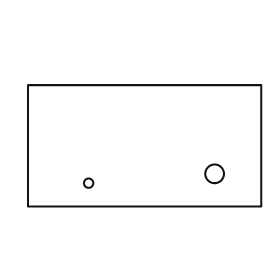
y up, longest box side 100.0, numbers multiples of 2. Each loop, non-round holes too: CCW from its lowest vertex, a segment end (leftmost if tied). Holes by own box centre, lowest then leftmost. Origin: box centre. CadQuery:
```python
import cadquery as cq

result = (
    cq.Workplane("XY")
    .moveTo(-50.0, -26.0)
    .lineTo(50.0, -26.0)
    .lineTo(50.0, 26.0)
    .lineTo(-50.0, 26.0)
    .close()
    .moveTo(-24.0, -16.0)
    .circle(2.0)
    .moveTo(30.0, -12.0)
    .circle(4.0)
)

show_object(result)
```